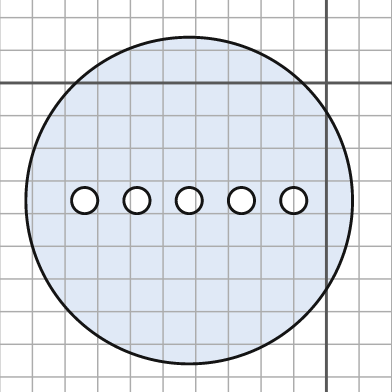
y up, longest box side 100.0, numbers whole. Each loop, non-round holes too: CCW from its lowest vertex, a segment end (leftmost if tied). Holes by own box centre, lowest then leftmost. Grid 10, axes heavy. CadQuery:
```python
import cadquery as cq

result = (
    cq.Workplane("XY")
    .moveTo(-42.0, -36.0)
    .circle(50.0)
    .moveTo(-74.0, -36.0)
    .circle(4.0)
    .moveTo(-58.0, -36.0)
    .circle(4.0)
    .moveTo(-42.0, -36.0)
    .circle(4.0)
    .moveTo(-26.0, -36.0)
    .circle(4.0)
    .moveTo(-10.0, -36.0)
    .circle(4.0)
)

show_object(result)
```